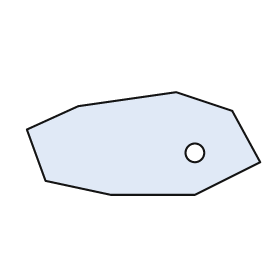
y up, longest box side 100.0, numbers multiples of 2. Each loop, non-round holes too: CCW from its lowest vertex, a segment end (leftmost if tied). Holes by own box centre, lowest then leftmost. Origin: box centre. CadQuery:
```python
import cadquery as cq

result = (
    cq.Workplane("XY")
    .moveTo(-14.0, -22.0)
    .lineTo(22.0, -22.0)
    .lineTo(50.0, -8.0)
    .lineTo(38.0, 14.0)
    .lineTo(14.0, 22.0)
    .lineTo(-28.0, 16.0)
    .lineTo(-50.0, 6.0)
    .lineTo(-42.0, -16.0)
    .close()
    .moveTo(22.0, -4.0)
    .circle(4.0)
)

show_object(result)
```